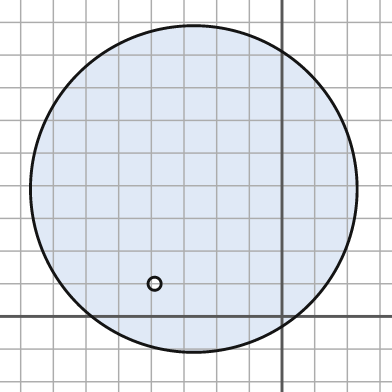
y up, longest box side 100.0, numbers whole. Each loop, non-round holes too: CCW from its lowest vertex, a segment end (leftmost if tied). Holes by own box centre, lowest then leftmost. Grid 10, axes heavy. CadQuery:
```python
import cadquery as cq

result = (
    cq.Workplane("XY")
    .moveTo(-27.0, 39.0)
    .circle(50.0)
    .moveTo(-39.0, 10.0)
    .circle(2.0)
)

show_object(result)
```